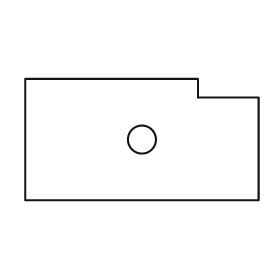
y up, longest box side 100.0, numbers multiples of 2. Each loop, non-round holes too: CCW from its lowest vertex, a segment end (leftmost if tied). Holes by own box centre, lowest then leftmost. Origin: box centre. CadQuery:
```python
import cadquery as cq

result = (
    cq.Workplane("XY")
    .moveTo(-50.0, -26.0)
    .lineTo(50.0, -26.0)
    .lineTo(50.0, 18.0)
    .lineTo(24.0, 18.0)
    .lineTo(24.0, 26.0)
    .lineTo(-50.0, 26.0)
    .close()
    .moveTo(0.0, 0.0)
    .circle(6.0)
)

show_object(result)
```